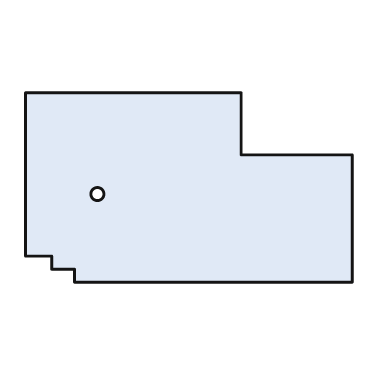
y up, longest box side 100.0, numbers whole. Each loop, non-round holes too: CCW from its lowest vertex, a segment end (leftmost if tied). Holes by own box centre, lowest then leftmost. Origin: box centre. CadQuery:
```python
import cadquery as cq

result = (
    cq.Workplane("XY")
    .moveTo(-35.0, -29.0)
    .lineTo(50.0, -29.0)
    .lineTo(50.0, 10.0)
    .lineTo(16.0, 10.0)
    .lineTo(16.0, 29.0)
    .lineTo(-50.0, 29.0)
    .lineTo(-50.0, -21.0)
    .lineTo(-42.0, -21.0)
    .lineTo(-42.0, -25.0)
    .lineTo(-35.0, -25.0)
    .close()
    .moveTo(-28.0, -2.0)
    .circle(2.0)
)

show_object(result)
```